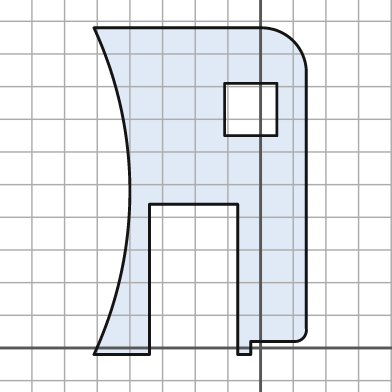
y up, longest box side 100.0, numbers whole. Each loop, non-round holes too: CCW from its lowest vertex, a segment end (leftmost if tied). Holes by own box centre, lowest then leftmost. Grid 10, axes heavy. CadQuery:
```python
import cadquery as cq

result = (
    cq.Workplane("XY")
    .moveTo(-51.0, -2.0)
    .lineTo(-34.0, -2.0)
    .lineTo(-34.0, 44.0)
    .lineTo(-7.0, 44.0)
    .lineTo(-7.0, -2.0)
    .lineTo(-3.0, -2.0)
    .lineTo(-3.0, 2.0)
    .lineTo(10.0, 2.0)
    .threePointArc((13.0, 3.0), (14.0, 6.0))
    .lineTo(14.0, 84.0)
    .threePointArc((10.0, 94.0), (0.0, 98.0))
    .lineTo(-51.0, 98.0)
    .threePointArc((-40.0, 48.0), (-51.0, -2.0))
    .close()
    .moveTo(-11.0, 65.0)
    .lineTo(5.0, 65.0)
    .lineTo(5.0, 81.0)
    .lineTo(-11.0, 81.0)
    .close()
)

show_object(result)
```